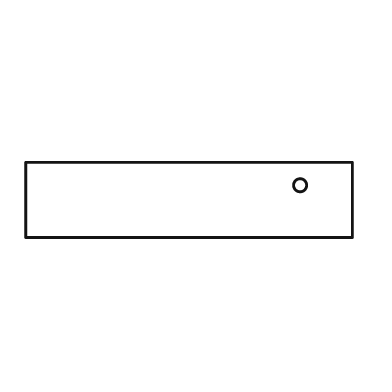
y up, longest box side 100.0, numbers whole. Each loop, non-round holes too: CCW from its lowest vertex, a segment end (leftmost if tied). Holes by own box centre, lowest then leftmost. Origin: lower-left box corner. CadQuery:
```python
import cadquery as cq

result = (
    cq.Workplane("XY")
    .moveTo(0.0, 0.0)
    .lineTo(100.0, 0.0)
    .lineTo(100.0, 23.0)
    .lineTo(0.0, 23.0)
    .close()
    .moveTo(84.0, 16.0)
    .circle(2.0)
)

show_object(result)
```